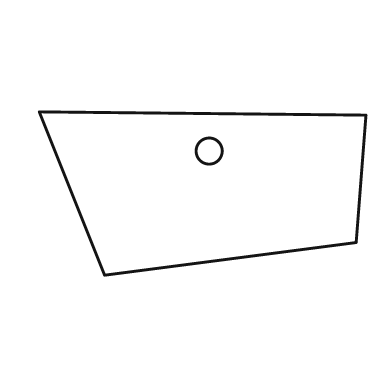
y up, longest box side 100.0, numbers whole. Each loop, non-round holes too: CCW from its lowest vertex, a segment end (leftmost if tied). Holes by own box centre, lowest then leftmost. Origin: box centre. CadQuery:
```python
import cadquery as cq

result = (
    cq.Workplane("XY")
    .moveTo(-30.0, -25.0)
    .lineTo(47.0, -15.0)
    .lineTo(50.0, 24.0)
    .lineTo(-50.0, 25.0)
    .close()
    .moveTo(2.0, 13.0)
    .circle(4.0)
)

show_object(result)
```